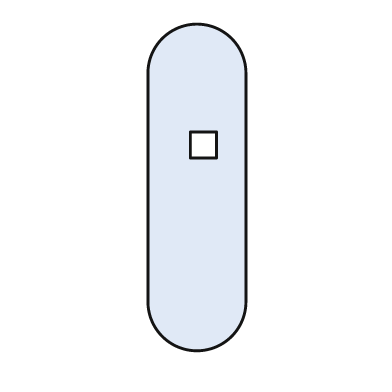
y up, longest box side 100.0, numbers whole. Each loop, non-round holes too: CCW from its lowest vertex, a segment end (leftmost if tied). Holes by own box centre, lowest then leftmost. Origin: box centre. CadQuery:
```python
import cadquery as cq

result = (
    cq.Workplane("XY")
    .moveTo(-15.0, -35.0)
    .threePointArc((0.0, -50.0), (15.0, -35.0))
    .lineTo(15.0, 35.0)
    .threePointArc((0.0, 50.0), (-15.0, 35.0))
    .close()
    .moveTo(-2.0, 9.0)
    .lineTo(6.0, 9.0)
    .lineTo(6.0, 17.0)
    .lineTo(-2.0, 17.0)
    .close()
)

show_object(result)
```